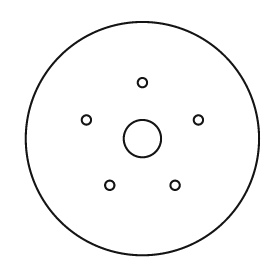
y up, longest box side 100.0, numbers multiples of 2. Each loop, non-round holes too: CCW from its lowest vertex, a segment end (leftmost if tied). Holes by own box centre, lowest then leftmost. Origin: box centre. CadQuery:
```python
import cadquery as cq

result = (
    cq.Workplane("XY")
    .moveTo(0.0, 0.0)
    .circle(50.0)
    .moveTo(-14.0, -20.0)
    .circle(2.0)
    .moveTo(14.0, -20.0)
    .circle(2.0)
    .moveTo(0.0, 0.0)
    .circle(8.0)
    .moveTo(-24.0, 8.0)
    .circle(2.0)
    .moveTo(24.0, 8.0)
    .circle(2.0)
    .moveTo(0.0, 24.0)
    .circle(2.0)
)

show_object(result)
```